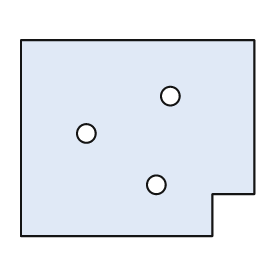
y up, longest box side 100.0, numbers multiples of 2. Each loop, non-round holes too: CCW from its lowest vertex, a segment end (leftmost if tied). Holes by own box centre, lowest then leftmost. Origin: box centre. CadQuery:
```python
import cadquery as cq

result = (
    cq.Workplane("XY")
    .moveTo(-50.0, -42.0)
    .lineTo(32.0, -42.0)
    .lineTo(32.0, -24.0)
    .lineTo(50.0, -24.0)
    .lineTo(50.0, 42.0)
    .lineTo(-50.0, 42.0)
    .close()
    .moveTo(8.0, -20.0)
    .circle(4.0)
    .moveTo(-22.0, 2.0)
    .circle(4.0)
    .moveTo(14.0, 18.0)
    .circle(4.0)
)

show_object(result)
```